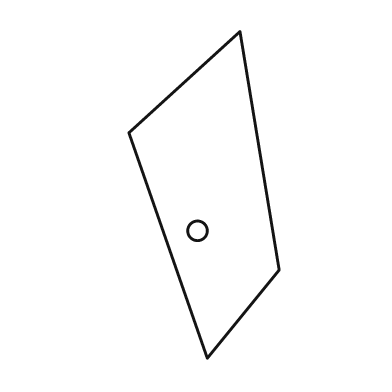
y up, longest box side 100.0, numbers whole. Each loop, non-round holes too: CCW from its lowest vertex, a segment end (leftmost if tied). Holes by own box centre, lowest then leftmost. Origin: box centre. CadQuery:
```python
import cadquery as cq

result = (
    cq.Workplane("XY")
    .moveTo(1.0, -50.0)
    .lineTo(23.0, -23.0)
    .lineTo(11.0, 50.0)
    .lineTo(-23.0, 19.0)
    .close()
    .moveTo(-2.0, -11.0)
    .circle(3.0)
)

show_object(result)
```